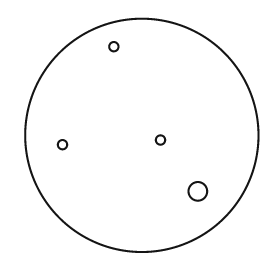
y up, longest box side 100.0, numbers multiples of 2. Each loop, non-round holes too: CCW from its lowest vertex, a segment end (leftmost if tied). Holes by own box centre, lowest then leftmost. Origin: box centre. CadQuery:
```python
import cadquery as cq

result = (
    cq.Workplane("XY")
    .moveTo(0.0, 0.0)
    .circle(50.0)
    .moveTo(24.0, -24.0)
    .circle(4.0)
    .moveTo(-34.0, -4.0)
    .circle(2.0)
    .moveTo(8.0, -2.0)
    .circle(2.0)
    .moveTo(-12.0, 38.0)
    .circle(2.0)
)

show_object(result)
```